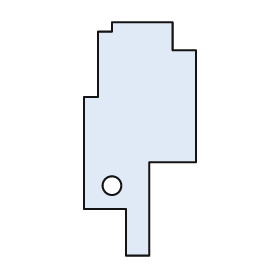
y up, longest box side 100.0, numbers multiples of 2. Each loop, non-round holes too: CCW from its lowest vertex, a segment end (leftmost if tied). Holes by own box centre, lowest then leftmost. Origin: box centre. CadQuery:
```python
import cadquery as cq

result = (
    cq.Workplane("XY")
    .moveTo(-6.0, -50.0)
    .lineTo(4.0, -50.0)
    .lineTo(4.0, -10.0)
    .lineTo(24.0, -10.0)
    .lineTo(24.0, 38.0)
    .lineTo(14.0, 38.0)
    .lineTo(14.0, 50.0)
    .lineTo(-12.0, 50.0)
    .lineTo(-12.0, 46.0)
    .lineTo(-18.0, 46.0)
    .lineTo(-18.0, 18.0)
    .lineTo(-24.0, 18.0)
    .lineTo(-24.0, -30.0)
    .lineTo(-6.0, -30.0)
    .close()
    .moveTo(-12.0, -20.0)
    .circle(4.0)
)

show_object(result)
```